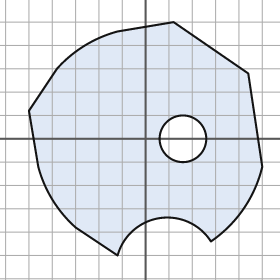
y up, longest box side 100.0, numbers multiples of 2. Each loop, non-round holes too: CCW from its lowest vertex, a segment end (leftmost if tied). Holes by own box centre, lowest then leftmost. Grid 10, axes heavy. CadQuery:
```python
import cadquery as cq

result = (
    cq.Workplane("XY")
    .moveTo(-12.0, -50.0)
    .threePointArc((6.0, -34.0), (28.0, -44.0))
    .threePointArc((42.0, -30.0), (50.0, -12.0))
    .lineTo(44.0, 28.0)
    .lineTo(12.0, 50.0)
    .lineTo(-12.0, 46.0)
    .threePointArc((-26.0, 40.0), (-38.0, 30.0))
    .lineTo(-50.0, 12.0)
    .lineTo(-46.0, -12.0)
    .threePointArc((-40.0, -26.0), (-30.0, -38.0))
    .close()
    .moveTo(16.0, 0.0)
    .circle(10.0)
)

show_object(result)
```